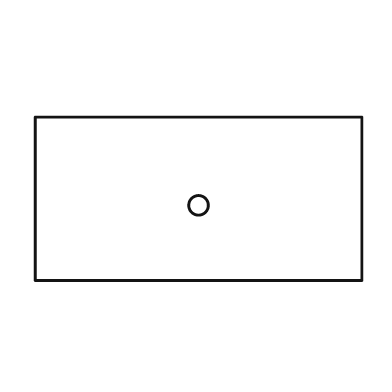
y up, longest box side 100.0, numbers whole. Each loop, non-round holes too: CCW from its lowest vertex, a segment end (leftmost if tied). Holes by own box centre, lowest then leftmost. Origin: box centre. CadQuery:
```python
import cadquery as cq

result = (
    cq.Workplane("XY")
    .moveTo(-50.0, -25.0)
    .lineTo(50.0, -25.0)
    .lineTo(50.0, 25.0)
    .lineTo(-50.0, 25.0)
    .close()
    .moveTo(0.0, -2.0)
    .circle(3.0)
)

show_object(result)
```